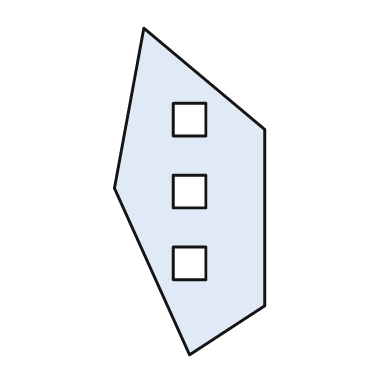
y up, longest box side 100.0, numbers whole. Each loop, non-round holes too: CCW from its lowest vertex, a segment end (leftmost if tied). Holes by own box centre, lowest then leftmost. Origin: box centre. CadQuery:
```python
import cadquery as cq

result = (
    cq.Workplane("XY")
    .moveTo(0.0, -50.0)
    .lineTo(23.0, -35.0)
    .lineTo(23.0, 19.0)
    .lineTo(-14.0, 50.0)
    .lineTo(-23.0, 1.0)
    .close()
    .moveTo(-5.0, -27.0)
    .lineTo(5.0, -27.0)
    .lineTo(5.0, -17.0)
    .lineTo(-5.0, -17.0)
    .close()
    .moveTo(-5.0, -5.0)
    .lineTo(5.0, -5.0)
    .lineTo(5.0, 5.0)
    .lineTo(-5.0, 5.0)
    .close()
    .moveTo(-5.0, 17.0)
    .lineTo(5.0, 17.0)
    .lineTo(5.0, 27.0)
    .lineTo(-5.0, 27.0)
    .close()
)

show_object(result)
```